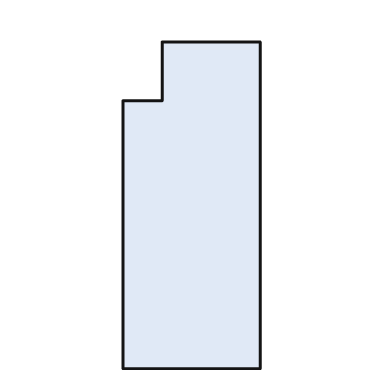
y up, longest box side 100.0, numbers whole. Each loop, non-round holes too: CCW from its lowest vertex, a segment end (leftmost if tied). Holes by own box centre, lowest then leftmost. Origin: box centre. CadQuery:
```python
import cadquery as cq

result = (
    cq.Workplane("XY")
    .moveTo(-21.0, -50.0)
    .lineTo(21.0, -50.0)
    .lineTo(21.0, 50.0)
    .lineTo(-9.0, 50.0)
    .lineTo(-9.0, 32.0)
    .lineTo(-21.0, 32.0)
    .close()
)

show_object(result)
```